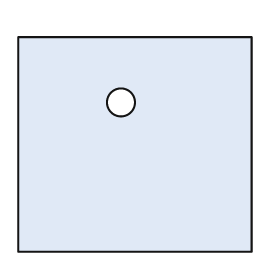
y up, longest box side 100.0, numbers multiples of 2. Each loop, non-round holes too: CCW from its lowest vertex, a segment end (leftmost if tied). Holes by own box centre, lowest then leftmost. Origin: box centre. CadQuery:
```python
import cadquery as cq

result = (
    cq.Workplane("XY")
    .moveTo(-50.0, -46.0)
    .lineTo(50.0, -46.0)
    .lineTo(50.0, 46.0)
    .lineTo(-50.0, 46.0)
    .close()
    .moveTo(-6.0, 18.0)
    .circle(6.0)
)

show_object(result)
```